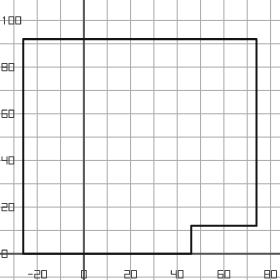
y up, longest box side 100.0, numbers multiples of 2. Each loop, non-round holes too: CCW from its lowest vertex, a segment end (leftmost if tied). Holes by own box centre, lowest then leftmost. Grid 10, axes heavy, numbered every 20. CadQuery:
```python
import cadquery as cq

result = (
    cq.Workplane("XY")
    .moveTo(-26.0, 0.0)
    .lineTo(46.0, 0.0)
    .lineTo(46.0, 12.0)
    .lineTo(74.0, 12.0)
    .lineTo(74.0, 92.0)
    .lineTo(-26.0, 92.0)
    .close()
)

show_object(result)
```